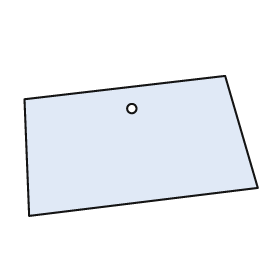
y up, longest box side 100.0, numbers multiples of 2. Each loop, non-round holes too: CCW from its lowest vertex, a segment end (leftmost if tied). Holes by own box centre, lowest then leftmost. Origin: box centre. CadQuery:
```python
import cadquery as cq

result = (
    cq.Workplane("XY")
    .moveTo(-48.0, -30.0)
    .lineTo(50.0, -18.0)
    .lineTo(36.0, 30.0)
    .lineTo(-50.0, 20.0)
    .close()
    .moveTo(-4.0, 16.0)
    .circle(2.0)
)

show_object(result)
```